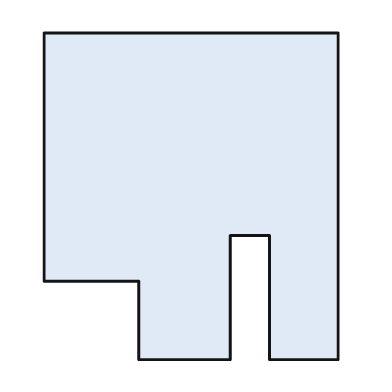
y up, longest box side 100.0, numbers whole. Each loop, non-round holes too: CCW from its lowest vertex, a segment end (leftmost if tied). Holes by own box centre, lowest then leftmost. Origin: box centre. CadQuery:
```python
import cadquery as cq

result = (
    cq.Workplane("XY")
    .moveTo(-16.0, -50.0)
    .lineTo(12.0, -50.0)
    .lineTo(12.0, -12.0)
    .lineTo(24.0, -12.0)
    .lineTo(24.0, -50.0)
    .lineTo(45.0, -50.0)
    .lineTo(45.0, 50.0)
    .lineTo(-45.0, 50.0)
    .lineTo(-45.0, -26.0)
    .lineTo(-16.0, -26.0)
    .close()
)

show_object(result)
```